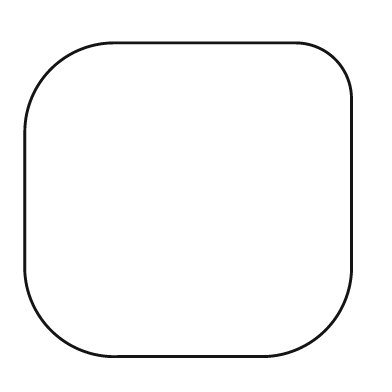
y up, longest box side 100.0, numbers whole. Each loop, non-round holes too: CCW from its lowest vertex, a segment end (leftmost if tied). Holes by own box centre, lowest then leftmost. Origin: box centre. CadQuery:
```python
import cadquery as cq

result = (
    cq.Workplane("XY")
    .moveTo(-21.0, -48.0)
    .lineTo(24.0, -48.0)
    .threePointArc((42.0, -40.0), (50.0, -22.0))
    .lineTo(50.0, 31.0)
    .threePointArc((45.0, 43.0), (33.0, 48.0))
    .lineTo(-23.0, 48.0)
    .threePointArc((-42.0, 40.0), (-50.0, 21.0))
    .lineTo(-50.0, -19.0)
    .threePointArc((-42.0, -40.0), (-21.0, -48.0))
    .close()
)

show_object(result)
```